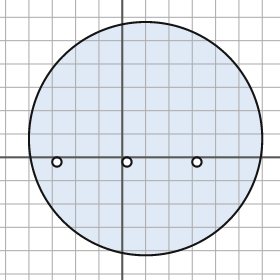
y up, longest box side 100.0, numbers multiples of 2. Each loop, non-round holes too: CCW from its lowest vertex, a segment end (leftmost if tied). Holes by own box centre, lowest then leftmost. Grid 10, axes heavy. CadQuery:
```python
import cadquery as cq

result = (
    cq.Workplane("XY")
    .moveTo(10.0, 8.0)
    .circle(50.0)
    .moveTo(-28.0, -2.0)
    .circle(2.0)
    .moveTo(2.0, -2.0)
    .circle(2.0)
    .moveTo(32.0, -2.0)
    .circle(2.0)
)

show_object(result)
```